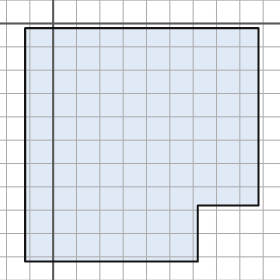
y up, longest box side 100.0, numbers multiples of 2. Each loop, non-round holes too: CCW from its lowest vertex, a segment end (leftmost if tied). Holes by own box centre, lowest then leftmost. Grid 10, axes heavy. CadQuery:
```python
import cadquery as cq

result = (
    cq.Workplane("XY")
    .moveTo(-12.0, -102.0)
    .lineTo(62.0, -102.0)
    .lineTo(62.0, -78.0)
    .lineTo(88.0, -78.0)
    .lineTo(88.0, -2.0)
    .lineTo(-12.0, -2.0)
    .close()
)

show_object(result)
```